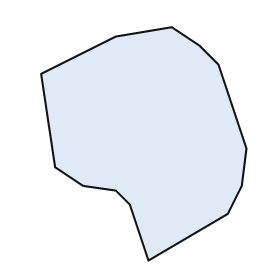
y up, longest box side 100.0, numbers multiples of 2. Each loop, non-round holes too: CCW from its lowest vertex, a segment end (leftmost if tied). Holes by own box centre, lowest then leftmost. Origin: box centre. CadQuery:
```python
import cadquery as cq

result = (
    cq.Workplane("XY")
    .moveTo(2.0, -50.0)
    .lineTo(36.0, -30.0)
    .lineTo(42.0, -18.0)
    .lineTo(44.0, -2.0)
    .lineTo(32.0, 34.0)
    .lineTo(24.0, 42.0)
    .lineTo(12.0, 50.0)
    .lineTo(-12.0, 46.0)
    .lineTo(-44.0, 30.0)
    .lineTo(-38.0, -10.0)
    .lineTo(-26.0, -18.0)
    .lineTo(-12.0, -20.0)
    .lineTo(-6.0, -26.0)
    .close()
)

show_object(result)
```